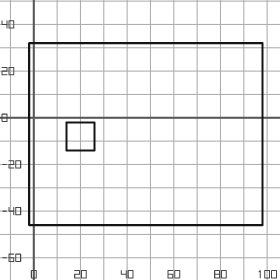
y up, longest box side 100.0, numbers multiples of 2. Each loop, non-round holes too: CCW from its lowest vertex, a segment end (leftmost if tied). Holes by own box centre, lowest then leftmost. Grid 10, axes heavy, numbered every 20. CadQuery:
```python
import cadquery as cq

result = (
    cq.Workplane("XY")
    .moveTo(-2.0, -46.0)
    .lineTo(98.0, -46.0)
    .lineTo(98.0, 32.0)
    .lineTo(-2.0, 32.0)
    .close()
    .moveTo(14.0, -14.0)
    .lineTo(26.0, -14.0)
    .lineTo(26.0, -2.0)
    .lineTo(14.0, -2.0)
    .close()
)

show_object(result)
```